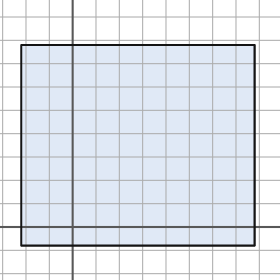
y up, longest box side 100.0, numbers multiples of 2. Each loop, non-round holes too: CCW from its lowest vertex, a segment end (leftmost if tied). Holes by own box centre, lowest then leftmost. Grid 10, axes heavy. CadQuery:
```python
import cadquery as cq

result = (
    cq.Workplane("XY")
    .moveTo(-22.0, -8.0)
    .lineTo(78.0, -8.0)
    .lineTo(78.0, 78.0)
    .lineTo(-22.0, 78.0)
    .close()
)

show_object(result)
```